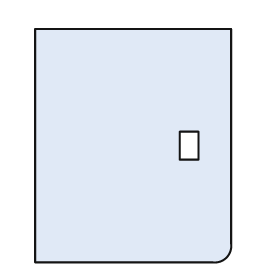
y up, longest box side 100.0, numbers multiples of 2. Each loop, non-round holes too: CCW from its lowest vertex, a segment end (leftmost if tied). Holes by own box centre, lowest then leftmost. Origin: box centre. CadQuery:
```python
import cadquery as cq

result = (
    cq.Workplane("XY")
    .moveTo(-42.0, -50.0)
    .lineTo(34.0, -50.0)
    .threePointArc((40.0, -48.0), (42.0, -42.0))
    .lineTo(42.0, 50.0)
    .lineTo(-42.0, 50.0)
    .close()
    .moveTo(20.0, -6.0)
    .lineTo(28.0, -6.0)
    .lineTo(28.0, 6.0)
    .lineTo(20.0, 6.0)
    .close()
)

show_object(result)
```